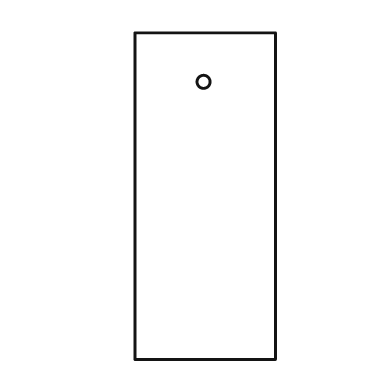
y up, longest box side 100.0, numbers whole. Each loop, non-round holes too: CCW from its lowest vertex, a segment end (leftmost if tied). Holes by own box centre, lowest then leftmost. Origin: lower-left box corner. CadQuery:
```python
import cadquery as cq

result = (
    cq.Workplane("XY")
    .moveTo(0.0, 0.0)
    .lineTo(43.0, 0.0)
    .lineTo(43.0, 100.0)
    .lineTo(0.0, 100.0)
    .close()
    .moveTo(21.0, 85.0)
    .circle(2.0)
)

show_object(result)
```